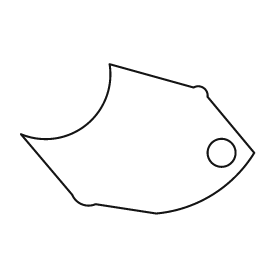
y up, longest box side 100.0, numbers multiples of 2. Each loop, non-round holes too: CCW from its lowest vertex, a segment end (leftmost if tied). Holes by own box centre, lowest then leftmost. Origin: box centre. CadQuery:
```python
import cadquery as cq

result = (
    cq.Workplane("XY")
    .moveTo(8.0, -32.0)
    .threePointArc((32.0, -24.0), (50.0, -6.0))
    .lineTo(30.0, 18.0)
    .threePointArc((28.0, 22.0), (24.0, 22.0))
    .lineTo(-12.0, 32.0)
    .threePointArc((-22.0, 6.0), (-50.0, 2.0))
    .lineTo(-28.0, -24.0)
    .threePointArc((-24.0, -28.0), (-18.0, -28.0))
    .close()
    .moveTo(36.0, -6.0)
    .circle(6.0)
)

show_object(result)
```